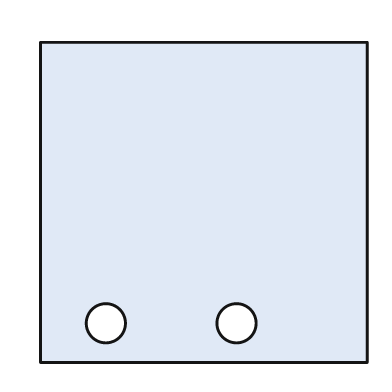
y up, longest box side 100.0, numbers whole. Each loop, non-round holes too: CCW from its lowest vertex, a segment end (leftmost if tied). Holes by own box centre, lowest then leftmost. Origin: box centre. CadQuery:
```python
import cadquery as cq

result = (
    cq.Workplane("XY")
    .moveTo(-50.0, -49.0)
    .lineTo(50.0, -49.0)
    .lineTo(50.0, 49.0)
    .lineTo(-50.0, 49.0)
    .close()
    .moveTo(-30.0, -37.0)
    .circle(6.0)
    .moveTo(10.0, -37.0)
    .circle(6.0)
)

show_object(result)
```